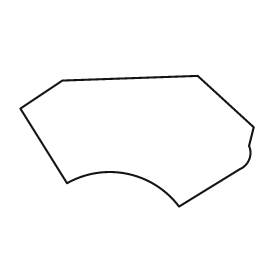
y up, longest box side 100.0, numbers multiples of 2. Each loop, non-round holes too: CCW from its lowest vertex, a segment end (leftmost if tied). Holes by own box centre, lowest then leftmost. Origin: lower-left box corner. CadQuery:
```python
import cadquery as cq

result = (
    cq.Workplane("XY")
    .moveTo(68.0, 0.0)
    .lineTo(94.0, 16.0)
    .threePointArc((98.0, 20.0), (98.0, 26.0))
    .lineTo(100.0, 34.0)
    .lineTo(76.0, 56.0)
    .lineTo(18.0, 54.0)
    .lineTo(0.0, 42.0)
    .lineTo(20.0, 10.0)
    .threePointArc((46.0, 14.0), (68.0, 0.0))
    .close()
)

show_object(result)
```